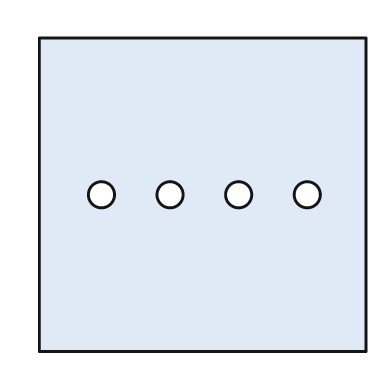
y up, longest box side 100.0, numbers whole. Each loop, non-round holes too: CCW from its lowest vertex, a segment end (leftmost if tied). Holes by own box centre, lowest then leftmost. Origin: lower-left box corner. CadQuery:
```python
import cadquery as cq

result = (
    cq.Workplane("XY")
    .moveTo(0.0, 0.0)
    .lineTo(100.0, 0.0)
    .lineTo(100.0, 96.0)
    .lineTo(0.0, 96.0)
    .close()
    .moveTo(19.0, 48.0)
    .circle(4.0)
    .moveTo(40.0, 48.0)
    .circle(4.0)
    .moveTo(61.0, 48.0)
    .circle(4.0)
    .moveTo(82.0, 48.0)
    .circle(4.0)
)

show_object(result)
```